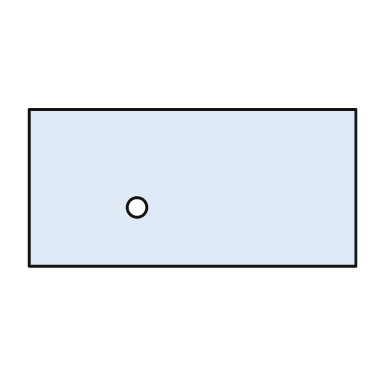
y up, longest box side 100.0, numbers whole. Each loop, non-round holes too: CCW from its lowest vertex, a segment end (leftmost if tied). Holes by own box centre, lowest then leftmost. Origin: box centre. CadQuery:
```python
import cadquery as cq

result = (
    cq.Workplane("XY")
    .moveTo(-50.0, -24.0)
    .lineTo(50.0, -24.0)
    .lineTo(50.0, 24.0)
    .lineTo(-50.0, 24.0)
    .close()
    .moveTo(-17.0, -6.0)
    .circle(3.0)
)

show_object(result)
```